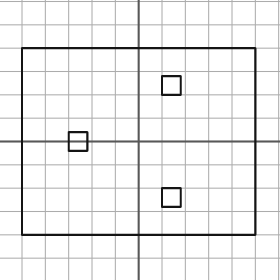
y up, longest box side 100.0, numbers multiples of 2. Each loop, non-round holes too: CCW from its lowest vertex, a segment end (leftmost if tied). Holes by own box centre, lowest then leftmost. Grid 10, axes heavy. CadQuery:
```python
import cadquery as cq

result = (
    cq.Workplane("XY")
    .moveTo(-50.0, -40.0)
    .lineTo(50.0, -40.0)
    .lineTo(50.0, 40.0)
    .lineTo(-50.0, 40.0)
    .close()
    .moveTo(10.0, -28.0)
    .lineTo(18.0, -28.0)
    .lineTo(18.0, -20.0)
    .lineTo(10.0, -20.0)
    .close()
    .moveTo(-30.0, -4.0)
    .lineTo(-22.0, -4.0)
    .lineTo(-22.0, 4.0)
    .lineTo(-30.0, 4.0)
    .close()
    .moveTo(10.0, 20.0)
    .lineTo(18.0, 20.0)
    .lineTo(18.0, 28.0)
    .lineTo(10.0, 28.0)
    .close()
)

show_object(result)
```